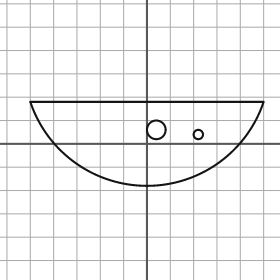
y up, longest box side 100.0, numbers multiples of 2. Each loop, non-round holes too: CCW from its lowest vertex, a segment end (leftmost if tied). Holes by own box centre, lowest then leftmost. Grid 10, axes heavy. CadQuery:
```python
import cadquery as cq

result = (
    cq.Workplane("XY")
    .moveTo(-50.0, 18.0)
    .threePointArc((0.0, -18.0), (50.0, 18.0))
    .close()
    .moveTo(22.0, 4.0)
    .circle(2.0)
    .moveTo(4.0, 6.0)
    .circle(4.0)
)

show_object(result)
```